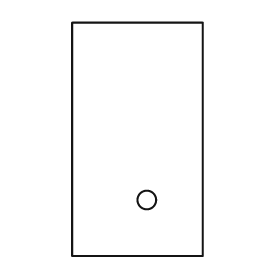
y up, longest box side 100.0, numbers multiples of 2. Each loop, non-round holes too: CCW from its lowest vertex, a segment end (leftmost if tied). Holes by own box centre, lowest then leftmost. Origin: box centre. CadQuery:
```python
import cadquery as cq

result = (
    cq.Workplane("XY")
    .moveTo(-28.0, -50.0)
    .lineTo(28.0, -50.0)
    .lineTo(28.0, 50.0)
    .lineTo(-28.0, 50.0)
    .close()
    .moveTo(4.0, -26.0)
    .circle(4.0)
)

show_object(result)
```